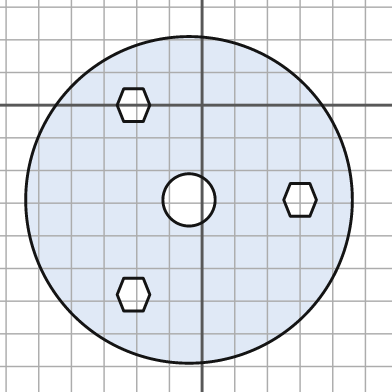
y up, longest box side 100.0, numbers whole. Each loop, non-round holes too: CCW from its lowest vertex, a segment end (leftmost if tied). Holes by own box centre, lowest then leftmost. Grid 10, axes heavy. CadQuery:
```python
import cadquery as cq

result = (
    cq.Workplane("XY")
    .moveTo(-4.0, -29.0)
    .circle(50.0)
    .moveTo(-24.0, -63.0)
    .lineTo(-18.0, -63.0)
    .lineTo(-16.0, -58.0)
    .lineTo(-18.0, -53.0)
    .lineTo(-24.0, -53.0)
    .lineTo(-26.0, -58.0)
    .close()
    .moveTo(-4.0, -29.0)
    .circle(8.0)
    .moveTo(27.0, -34.0)
    .lineTo(33.0, -34.0)
    .lineTo(35.0, -29.0)
    .lineTo(33.0, -24.0)
    .lineTo(27.0, -24.0)
    .lineTo(25.0, -29.0)
    .close()
    .moveTo(-24.0, -5.0)
    .lineTo(-18.0, -5.0)
    .lineTo(-16.0, 0.0)
    .lineTo(-18.0, 5.0)
    .lineTo(-24.0, 5.0)
    .lineTo(-26.0, 0.0)
    .close()
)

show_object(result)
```